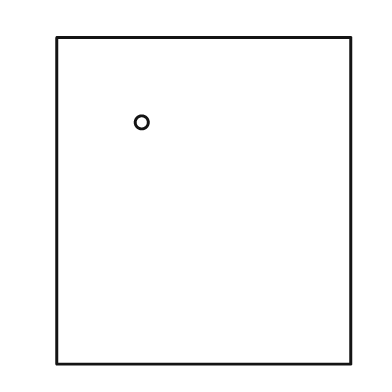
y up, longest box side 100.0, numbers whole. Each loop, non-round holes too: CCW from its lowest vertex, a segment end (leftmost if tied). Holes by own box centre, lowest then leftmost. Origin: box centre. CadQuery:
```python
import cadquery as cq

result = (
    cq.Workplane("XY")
    .moveTo(-45.0, -50.0)
    .lineTo(45.0, -50.0)
    .lineTo(45.0, 50.0)
    .lineTo(-45.0, 50.0)
    .close()
    .moveTo(-19.0, 24.0)
    .circle(2.0)
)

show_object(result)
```